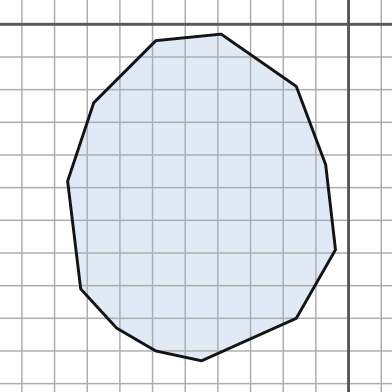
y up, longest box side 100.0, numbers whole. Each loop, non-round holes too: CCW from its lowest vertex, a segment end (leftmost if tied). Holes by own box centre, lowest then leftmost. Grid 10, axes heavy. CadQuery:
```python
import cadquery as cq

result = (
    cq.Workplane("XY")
    .moveTo(-45.0, -103.0)
    .lineTo(-16.0, -90.0)
    .lineTo(-4.0, -69.0)
    .lineTo(-7.0, -43.0)
    .lineTo(-16.0, -19.0)
    .lineTo(-39.0, -3.0)
    .lineTo(-59.0, -5.0)
    .lineTo(-78.0, -24.0)
    .lineTo(-86.0, -48.0)
    .lineTo(-82.0, -81.0)
    .lineTo(-71.0, -93.0)
    .lineTo(-59.0, -100.0)
    .close()
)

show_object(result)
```